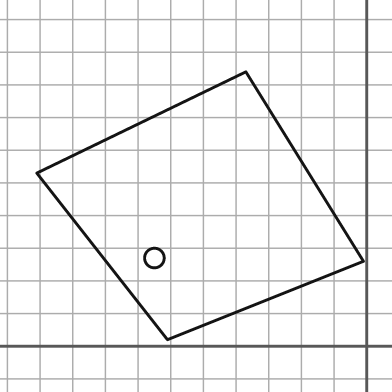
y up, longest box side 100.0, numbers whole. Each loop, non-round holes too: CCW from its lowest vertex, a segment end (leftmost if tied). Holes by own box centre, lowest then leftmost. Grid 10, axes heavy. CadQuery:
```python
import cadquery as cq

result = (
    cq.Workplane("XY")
    .moveTo(-61.0, 2.0)
    .lineTo(-1.0, 26.0)
    .lineTo(-37.0, 84.0)
    .lineTo(-101.0, 53.0)
    .close()
    .moveTo(-65.0, 27.0)
    .circle(3.0)
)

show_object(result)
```